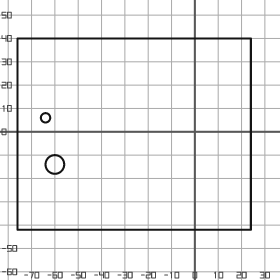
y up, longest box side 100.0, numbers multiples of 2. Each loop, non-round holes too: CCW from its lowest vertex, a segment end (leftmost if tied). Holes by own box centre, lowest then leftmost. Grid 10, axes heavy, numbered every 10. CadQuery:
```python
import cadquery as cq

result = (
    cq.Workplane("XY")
    .moveTo(-76.0, -42.0)
    .lineTo(24.0, -42.0)
    .lineTo(24.0, 40.0)
    .lineTo(-76.0, 40.0)
    .close()
    .moveTo(-60.0, -14.0)
    .circle(4.0)
    .moveTo(-64.0, 6.0)
    .circle(2.0)
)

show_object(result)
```